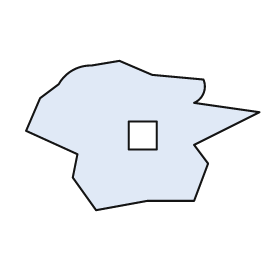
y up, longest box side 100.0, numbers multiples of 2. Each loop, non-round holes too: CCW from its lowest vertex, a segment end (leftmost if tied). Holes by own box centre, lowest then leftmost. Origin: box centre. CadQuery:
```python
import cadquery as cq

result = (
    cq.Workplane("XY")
    .moveTo(-20.0, -32.0)
    .lineTo(2.0, -28.0)
    .lineTo(22.0, -28.0)
    .lineTo(28.0, -12.0)
    .lineTo(22.0, -4.0)
    .lineTo(50.0, 10.0)
    .lineTo(22.0, 14.0)
    .threePointArc((26.0, 18.0), (26.0, 24.0))
    .lineTo(4.0, 26.0)
    .lineTo(-10.0, 32.0)
    .lineTo(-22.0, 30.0)
    .threePointArc((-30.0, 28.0), (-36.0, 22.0))
    .lineTo(-44.0, 16.0)
    .lineTo(-50.0, 2.0)
    .lineTo(-28.0, -8.0)
    .lineTo(-30.0, -18.0)
    .close()
    .moveTo(-6.0, -6.0)
    .lineTo(6.0, -6.0)
    .lineTo(6.0, 6.0)
    .lineTo(-6.0, 6.0)
    .close()
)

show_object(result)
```